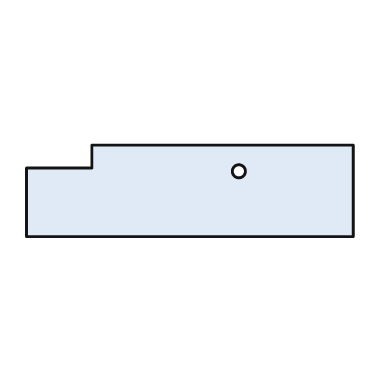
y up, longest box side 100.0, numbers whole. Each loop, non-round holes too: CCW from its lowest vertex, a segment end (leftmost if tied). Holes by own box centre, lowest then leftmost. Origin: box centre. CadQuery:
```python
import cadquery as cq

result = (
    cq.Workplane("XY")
    .moveTo(-50.0, -14.0)
    .lineTo(50.0, -14.0)
    .lineTo(50.0, 14.0)
    .lineTo(-30.0, 14.0)
    .lineTo(-30.0, 7.0)
    .lineTo(-50.0, 7.0)
    .close()
    .moveTo(15.0, 6.0)
    .circle(2.0)
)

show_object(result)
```